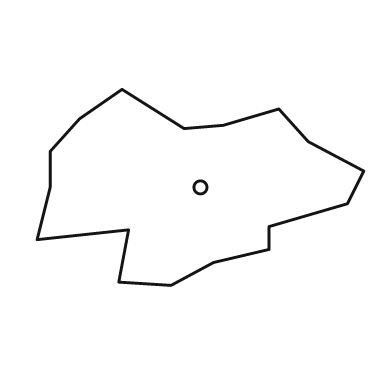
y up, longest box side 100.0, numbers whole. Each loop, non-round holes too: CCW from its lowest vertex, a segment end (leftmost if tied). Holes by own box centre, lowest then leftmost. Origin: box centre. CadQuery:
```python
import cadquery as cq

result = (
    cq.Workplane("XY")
    .moveTo(-9.0, -30.0)
    .lineTo(4.0, -23.0)
    .lineTo(21.0, -19.0)
    .lineTo(21.0, -12.0)
    .lineTo(45.0, -5.0)
    .lineTo(50.0, 5.0)
    .lineTo(33.0, 14.0)
    .lineTo(24.0, 24.0)
    .lineTo(7.0, 19.0)
    .lineTo(-5.0, 18.0)
    .lineTo(-24.0, 30.0)
    .lineTo(-37.0, 21.0)
    .lineTo(-46.0, 11.0)
    .lineTo(-46.0, 0.0)
    .lineTo(-50.0, -16.0)
    .lineTo(-22.0, -13.0)
    .lineTo(-25.0, -29.0)
    .close()
    .moveTo(0.0, 0.0)
    .circle(2.0)
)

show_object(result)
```